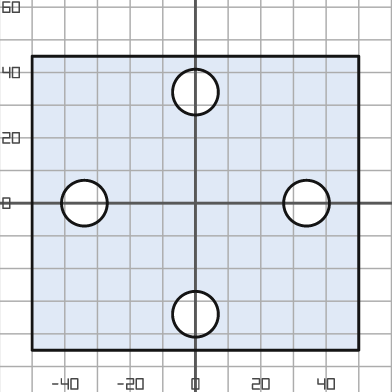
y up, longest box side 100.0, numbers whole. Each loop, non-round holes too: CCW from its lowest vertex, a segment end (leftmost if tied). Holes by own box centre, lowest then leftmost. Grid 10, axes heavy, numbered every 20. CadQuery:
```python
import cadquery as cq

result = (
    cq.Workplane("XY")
    .moveTo(-50.0, -45.0)
    .lineTo(50.0, -45.0)
    .lineTo(50.0, 45.0)
    .lineTo(-50.0, 45.0)
    .close()
    .moveTo(0.0, -34.0)
    .circle(7.0)
    .moveTo(-34.0, 0.0)
    .circle(7.0)
    .moveTo(34.0, 0.0)
    .circle(7.0)
    .moveTo(0.0, 34.0)
    .circle(7.0)
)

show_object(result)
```